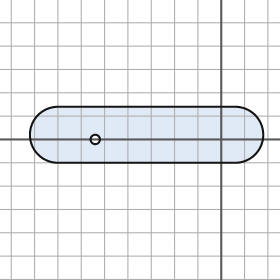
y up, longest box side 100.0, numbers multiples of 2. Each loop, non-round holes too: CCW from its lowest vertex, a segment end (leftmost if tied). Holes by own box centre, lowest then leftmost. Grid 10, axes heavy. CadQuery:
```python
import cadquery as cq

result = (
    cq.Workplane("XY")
    .moveTo(-70.0, -10.0)
    .lineTo(6.0, -10.0)
    .threePointArc((18.0, 2.0), (6.0, 14.0))
    .lineTo(-70.0, 14.0)
    .threePointArc((-82.0, 2.0), (-70.0, -10.0))
    .close()
    .moveTo(-54.0, 0.0)
    .circle(2.0)
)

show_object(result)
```